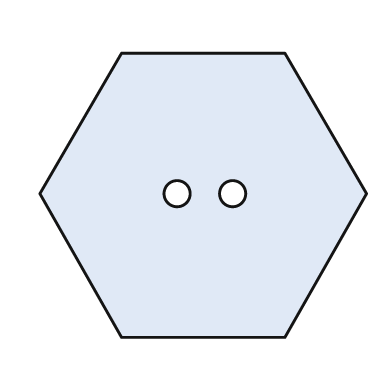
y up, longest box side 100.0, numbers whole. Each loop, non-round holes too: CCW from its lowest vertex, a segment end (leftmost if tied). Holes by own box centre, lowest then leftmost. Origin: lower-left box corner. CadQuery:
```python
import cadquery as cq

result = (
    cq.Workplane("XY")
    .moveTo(25.0, 0.0)
    .lineTo(75.0, 0.0)
    .lineTo(100.0, 44.0)
    .lineTo(75.0, 87.0)
    .lineTo(25.0, 87.0)
    .lineTo(0.0, 44.0)
    .close()
    .moveTo(42.0, 44.0)
    .circle(4.0)
    .moveTo(59.0, 44.0)
    .circle(4.0)
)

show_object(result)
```